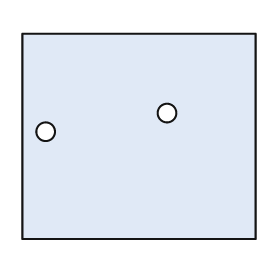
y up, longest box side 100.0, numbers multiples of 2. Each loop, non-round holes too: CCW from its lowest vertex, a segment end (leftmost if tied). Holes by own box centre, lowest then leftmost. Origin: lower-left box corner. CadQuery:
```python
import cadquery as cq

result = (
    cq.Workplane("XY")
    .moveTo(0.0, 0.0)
    .lineTo(100.0, 0.0)
    .lineTo(100.0, 88.0)
    .lineTo(0.0, 88.0)
    .close()
    .moveTo(10.0, 46.0)
    .circle(4.0)
    .moveTo(62.0, 54.0)
    .circle(4.0)
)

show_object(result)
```